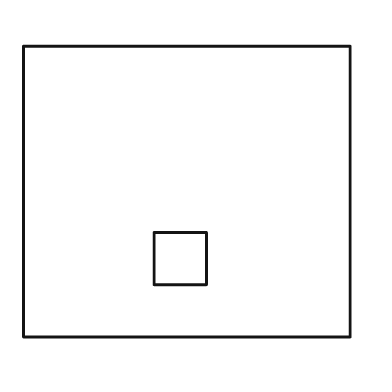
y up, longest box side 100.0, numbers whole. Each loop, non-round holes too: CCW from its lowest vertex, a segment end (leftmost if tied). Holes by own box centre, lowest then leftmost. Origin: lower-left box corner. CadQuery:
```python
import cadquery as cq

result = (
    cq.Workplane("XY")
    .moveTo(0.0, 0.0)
    .lineTo(100.0, 0.0)
    .lineTo(100.0, 89.0)
    .lineTo(0.0, 89.0)
    .close()
    .moveTo(40.0, 16.0)
    .lineTo(56.0, 16.0)
    .lineTo(56.0, 32.0)
    .lineTo(40.0, 32.0)
    .close()
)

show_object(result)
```